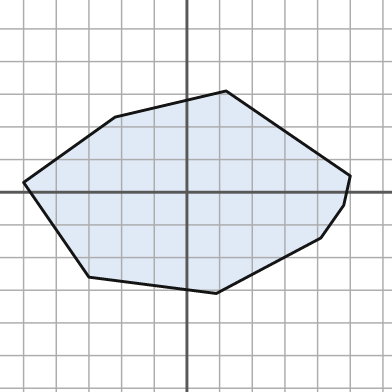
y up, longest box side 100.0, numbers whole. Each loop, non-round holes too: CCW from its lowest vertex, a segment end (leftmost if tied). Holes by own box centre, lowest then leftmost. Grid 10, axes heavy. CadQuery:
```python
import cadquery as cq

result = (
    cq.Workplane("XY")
    .moveTo(9.0, -31.0)
    .lineTo(41.0, -14.0)
    .lineTo(48.0, -4.0)
    .lineTo(50.0, 5.0)
    .lineTo(12.0, 31.0)
    .lineTo(-22.0, 23.0)
    .lineTo(-50.0, 3.0)
    .lineTo(-30.0, -26.0)
    .close()
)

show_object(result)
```